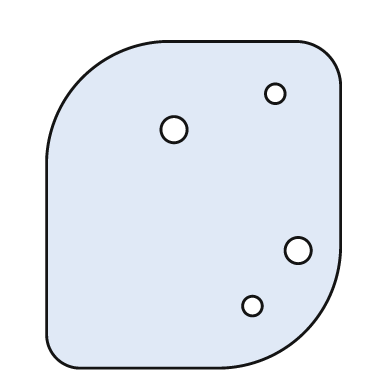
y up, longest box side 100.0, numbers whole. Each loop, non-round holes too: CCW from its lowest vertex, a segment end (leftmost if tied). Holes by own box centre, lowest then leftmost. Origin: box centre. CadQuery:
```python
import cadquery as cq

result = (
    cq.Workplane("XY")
    .moveTo(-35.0, -50.0)
    .lineTo(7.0, -50.0)
    .threePointArc((34.0, -39.0), (45.0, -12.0))
    .lineTo(45.0, 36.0)
    .threePointArc((41.0, 46.0), (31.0, 50.0))
    .lineTo(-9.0, 50.0)
    .threePointArc((-34.0, 39.0), (-45.0, 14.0))
    .lineTo(-45.0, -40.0)
    .threePointArc((-42.0, -47.0), (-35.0, -50.0))
    .close()
    .moveTo(18.0, -31.0)
    .circle(3.0)
    .moveTo(32.0, -14.0)
    .circle(4.0)
    .moveTo(-6.0, 23.0)
    .circle(4.0)
    .moveTo(25.0, 34.0)
    .circle(3.0)
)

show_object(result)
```